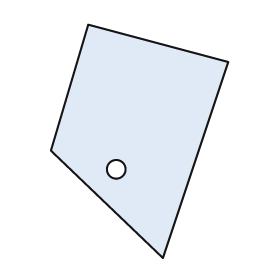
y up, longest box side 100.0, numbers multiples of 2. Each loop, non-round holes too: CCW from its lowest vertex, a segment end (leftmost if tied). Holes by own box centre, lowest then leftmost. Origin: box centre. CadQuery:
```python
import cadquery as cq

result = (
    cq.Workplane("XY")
    .moveTo(10.0, -50.0)
    .lineTo(38.0, 34.0)
    .lineTo(-22.0, 50.0)
    .lineTo(-38.0, -4.0)
    .close()
    .moveTo(-10.0, -12.0)
    .circle(4.0)
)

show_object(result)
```